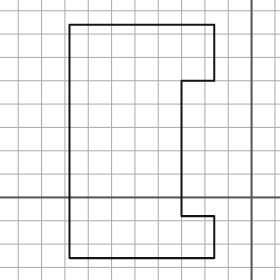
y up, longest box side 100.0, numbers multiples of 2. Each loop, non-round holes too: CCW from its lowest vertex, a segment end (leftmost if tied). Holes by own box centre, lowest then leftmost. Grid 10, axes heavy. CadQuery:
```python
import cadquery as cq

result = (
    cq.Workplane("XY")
    .moveTo(-78.0, -26.0)
    .lineTo(-16.0, -26.0)
    .lineTo(-16.0, -8.0)
    .lineTo(-30.0, -8.0)
    .lineTo(-30.0, 50.0)
    .lineTo(-16.0, 50.0)
    .lineTo(-16.0, 74.0)
    .lineTo(-78.0, 74.0)
    .close()
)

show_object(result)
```